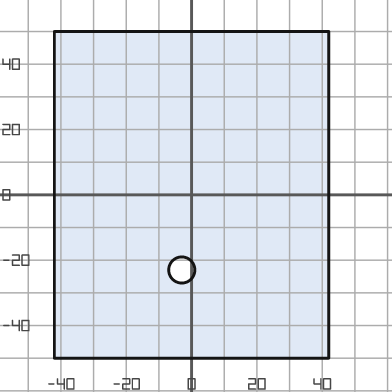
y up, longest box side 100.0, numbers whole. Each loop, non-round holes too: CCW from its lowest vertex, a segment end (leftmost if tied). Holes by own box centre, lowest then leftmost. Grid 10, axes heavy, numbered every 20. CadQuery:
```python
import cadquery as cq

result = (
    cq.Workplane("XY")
    .moveTo(-42.0, -50.0)
    .lineTo(42.0, -50.0)
    .lineTo(42.0, 50.0)
    .lineTo(-42.0, 50.0)
    .close()
    .moveTo(-3.0, -23.0)
    .circle(4.0)
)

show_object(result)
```